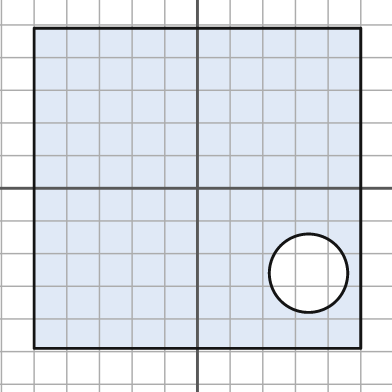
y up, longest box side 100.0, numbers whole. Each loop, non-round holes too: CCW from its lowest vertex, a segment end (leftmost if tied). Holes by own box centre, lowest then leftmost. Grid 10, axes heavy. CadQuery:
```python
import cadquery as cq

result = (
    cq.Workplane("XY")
    .moveTo(-50.0, -49.0)
    .lineTo(50.0, -49.0)
    .lineTo(50.0, 49.0)
    .lineTo(-50.0, 49.0)
    .close()
    .moveTo(34.0, -26.0)
    .circle(12.0)
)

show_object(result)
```